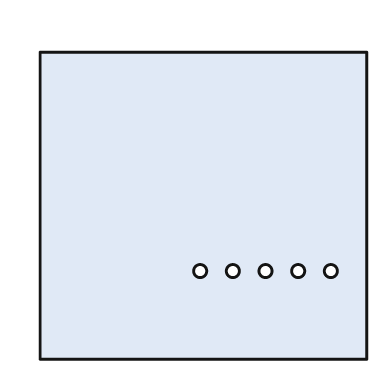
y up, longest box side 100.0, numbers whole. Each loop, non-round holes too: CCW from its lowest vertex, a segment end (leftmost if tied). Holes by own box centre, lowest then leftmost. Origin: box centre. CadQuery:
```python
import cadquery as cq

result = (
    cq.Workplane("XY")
    .moveTo(-50.0, -47.0)
    .lineTo(50.0, -47.0)
    .lineTo(50.0, 47.0)
    .lineTo(-50.0, 47.0)
    .close()
    .moveTo(-1.0, -20.0)
    .circle(2.0)
    .moveTo(9.0, -20.0)
    .circle(2.0)
    .moveTo(19.0, -20.0)
    .circle(2.0)
    .moveTo(29.0, -20.0)
    .circle(2.0)
    .moveTo(39.0, -20.0)
    .circle(2.0)
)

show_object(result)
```